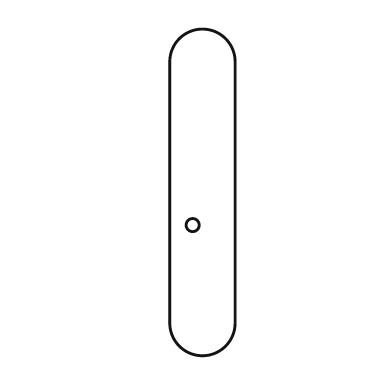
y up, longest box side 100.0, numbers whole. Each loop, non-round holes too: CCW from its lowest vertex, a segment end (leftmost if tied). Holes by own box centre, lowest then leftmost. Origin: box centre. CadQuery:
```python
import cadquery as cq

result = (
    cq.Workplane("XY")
    .moveTo(-10.0, -40.0)
    .threePointArc((0.0, -50.0), (10.0, -40.0))
    .lineTo(10.0, 40.0)
    .threePointArc((0.0, 50.0), (-10.0, 40.0))
    .close()
    .moveTo(-3.0, -10.0)
    .circle(2.0)
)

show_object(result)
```